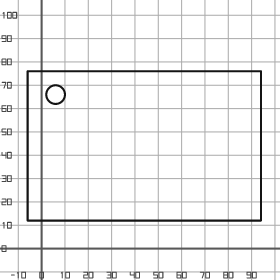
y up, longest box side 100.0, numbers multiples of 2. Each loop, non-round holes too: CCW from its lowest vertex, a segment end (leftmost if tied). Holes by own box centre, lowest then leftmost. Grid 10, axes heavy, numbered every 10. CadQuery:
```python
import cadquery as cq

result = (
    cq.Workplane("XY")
    .moveTo(-6.0, 12.0)
    .lineTo(94.0, 12.0)
    .lineTo(94.0, 76.0)
    .lineTo(-6.0, 76.0)
    .close()
    .moveTo(6.0, 66.0)
    .circle(4.0)
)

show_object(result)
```